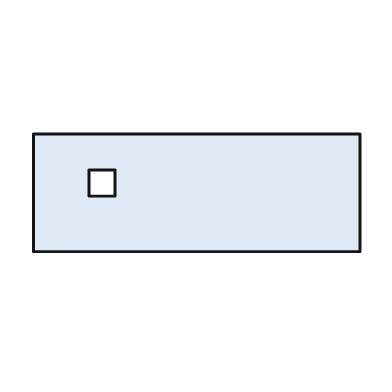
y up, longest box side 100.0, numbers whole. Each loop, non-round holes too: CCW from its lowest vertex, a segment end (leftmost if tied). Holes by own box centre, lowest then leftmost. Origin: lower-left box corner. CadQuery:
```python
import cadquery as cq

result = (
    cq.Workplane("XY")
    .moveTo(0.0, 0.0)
    .lineTo(100.0, 0.0)
    .lineTo(100.0, 36.0)
    .lineTo(0.0, 36.0)
    .close()
    .moveTo(17.0, 17.0)
    .lineTo(25.0, 17.0)
    .lineTo(25.0, 25.0)
    .lineTo(17.0, 25.0)
    .close()
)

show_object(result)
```